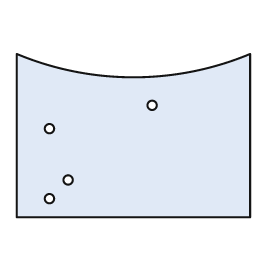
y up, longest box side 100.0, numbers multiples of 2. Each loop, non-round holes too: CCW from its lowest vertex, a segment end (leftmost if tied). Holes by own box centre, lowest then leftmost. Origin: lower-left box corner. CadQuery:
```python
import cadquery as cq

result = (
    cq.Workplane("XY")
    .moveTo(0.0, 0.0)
    .lineTo(100.0, 0.0)
    .lineTo(100.0, 70.0)
    .threePointArc((50.0, 60.0), (0.0, 70.0))
    .close()
    .moveTo(14.0, 8.0)
    .circle(2.0)
    .moveTo(22.0, 16.0)
    .circle(2.0)
    .moveTo(14.0, 38.0)
    .circle(2.0)
    .moveTo(58.0, 48.0)
    .circle(2.0)
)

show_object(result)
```